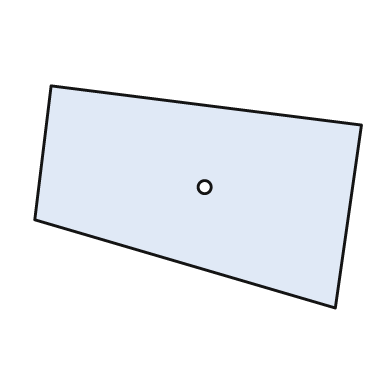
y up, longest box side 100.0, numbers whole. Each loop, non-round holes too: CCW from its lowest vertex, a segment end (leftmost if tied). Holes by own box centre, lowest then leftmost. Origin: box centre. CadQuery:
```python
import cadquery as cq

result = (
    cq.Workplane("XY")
    .moveTo(42.0, -34.0)
    .lineTo(50.0, 22.0)
    .lineTo(-45.0, 34.0)
    .lineTo(-50.0, -7.0)
    .close()
    .moveTo(2.0, 3.0)
    .circle(2.0)
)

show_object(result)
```